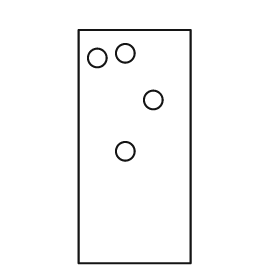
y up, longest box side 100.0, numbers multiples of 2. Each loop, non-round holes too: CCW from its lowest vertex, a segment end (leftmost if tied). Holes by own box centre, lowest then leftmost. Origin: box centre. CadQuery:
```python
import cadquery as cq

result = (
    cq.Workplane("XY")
    .moveTo(-24.0, -50.0)
    .lineTo(24.0, -50.0)
    .lineTo(24.0, 50.0)
    .lineTo(-24.0, 50.0)
    .close()
    .moveTo(-4.0, -2.0)
    .circle(4.0)
    .moveTo(8.0, 20.0)
    .circle(4.0)
    .moveTo(-16.0, 38.0)
    .circle(4.0)
    .moveTo(-4.0, 40.0)
    .circle(4.0)
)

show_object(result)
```